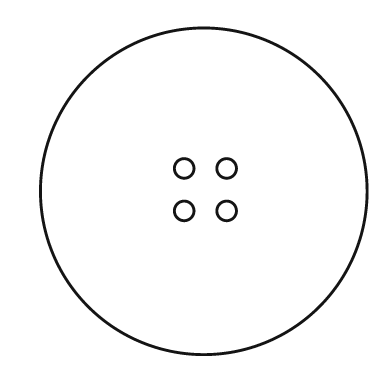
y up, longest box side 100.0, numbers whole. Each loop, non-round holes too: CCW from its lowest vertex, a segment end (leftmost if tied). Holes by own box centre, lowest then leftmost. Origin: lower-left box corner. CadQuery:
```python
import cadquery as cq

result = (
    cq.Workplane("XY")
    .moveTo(50.0, 50.0)
    .circle(50.0)
    .moveTo(44.0, 44.0)
    .circle(3.0)
    .moveTo(57.0, 44.0)
    .circle(3.0)
    .moveTo(44.0, 57.0)
    .circle(3.0)
    .moveTo(57.0, 57.0)
    .circle(3.0)
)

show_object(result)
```